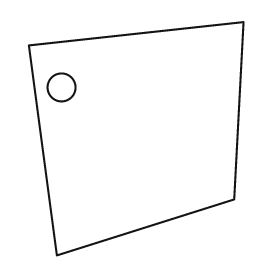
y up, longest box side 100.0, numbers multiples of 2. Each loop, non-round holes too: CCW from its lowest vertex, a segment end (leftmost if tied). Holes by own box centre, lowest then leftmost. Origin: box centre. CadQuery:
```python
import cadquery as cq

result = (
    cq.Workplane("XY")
    .moveTo(-34.0, -50.0)
    .lineTo(42.0, -26.0)
    .lineTo(46.0, 50.0)
    .lineTo(-46.0, 40.0)
    .close()
    .moveTo(-32.0, 22.0)
    .circle(6.0)
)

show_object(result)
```